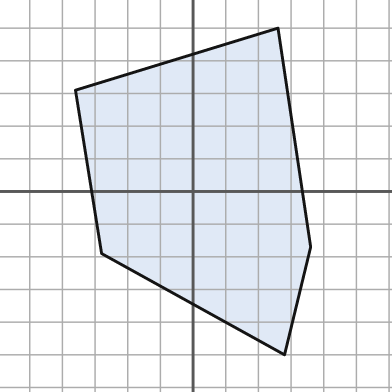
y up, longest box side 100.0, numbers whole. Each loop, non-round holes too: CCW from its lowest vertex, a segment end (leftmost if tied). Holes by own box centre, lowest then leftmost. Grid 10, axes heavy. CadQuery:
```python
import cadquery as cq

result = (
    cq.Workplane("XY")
    .moveTo(28.0, -50.0)
    .lineTo(36.0, -17.0)
    .lineTo(26.0, 50.0)
    .lineTo(-36.0, 31.0)
    .lineTo(-28.0, -19.0)
    .close()
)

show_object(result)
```